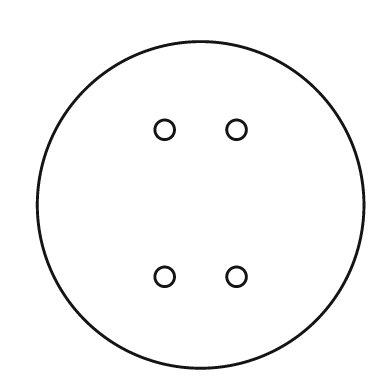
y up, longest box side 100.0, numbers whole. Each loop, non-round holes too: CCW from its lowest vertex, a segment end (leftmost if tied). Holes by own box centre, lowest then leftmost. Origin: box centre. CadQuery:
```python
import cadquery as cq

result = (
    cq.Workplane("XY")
    .moveTo(0.0, 0.0)
    .circle(50.0)
    .moveTo(-11.0, -22.0)
    .circle(3.0)
    .moveTo(11.0, -22.0)
    .circle(3.0)
    .moveTo(-11.0, 23.0)
    .circle(3.0)
    .moveTo(11.0, 23.0)
    .circle(3.0)
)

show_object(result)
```